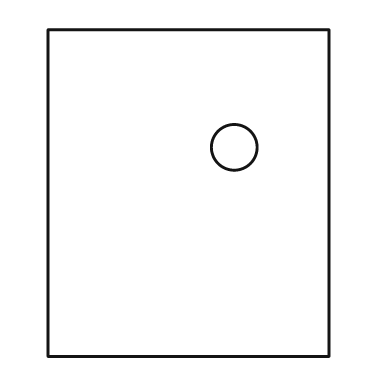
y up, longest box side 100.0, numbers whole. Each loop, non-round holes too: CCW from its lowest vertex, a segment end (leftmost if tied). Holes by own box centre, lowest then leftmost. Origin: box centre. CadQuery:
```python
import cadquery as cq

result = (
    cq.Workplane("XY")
    .moveTo(-43.0, -50.0)
    .lineTo(43.0, -50.0)
    .lineTo(43.0, 50.0)
    .lineTo(-43.0, 50.0)
    .close()
    .moveTo(14.0, 14.0)
    .circle(7.0)
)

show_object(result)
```